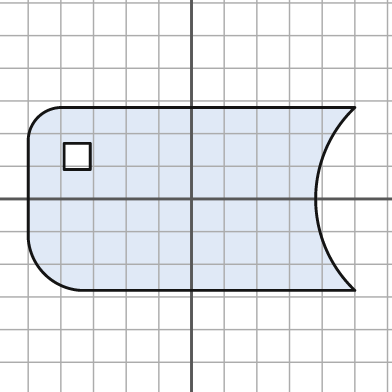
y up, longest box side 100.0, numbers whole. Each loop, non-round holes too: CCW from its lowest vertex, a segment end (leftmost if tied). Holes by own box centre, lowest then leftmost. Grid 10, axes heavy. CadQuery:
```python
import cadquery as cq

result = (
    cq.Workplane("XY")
    .moveTo(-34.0, -28.0)
    .lineTo(50.0, -28.0)
    .threePointArc((38.0, 0.0), (50.0, 28.0))
    .lineTo(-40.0, 28.0)
    .threePointArc((-47.0, 25.0), (-50.0, 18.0))
    .lineTo(-50.0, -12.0)
    .threePointArc((-45.0, -23.0), (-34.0, -28.0))
    .close()
    .moveTo(-39.0, 9.0)
    .lineTo(-31.0, 9.0)
    .lineTo(-31.0, 17.0)
    .lineTo(-39.0, 17.0)
    .close()
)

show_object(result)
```